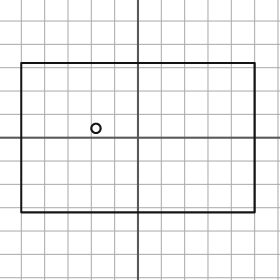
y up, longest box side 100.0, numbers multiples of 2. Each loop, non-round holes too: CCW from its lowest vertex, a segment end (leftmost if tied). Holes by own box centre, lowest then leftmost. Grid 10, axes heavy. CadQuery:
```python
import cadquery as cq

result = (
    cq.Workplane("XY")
    .moveTo(-50.0, -32.0)
    .lineTo(50.0, -32.0)
    .lineTo(50.0, 32.0)
    .lineTo(-50.0, 32.0)
    .close()
    .moveTo(-18.0, 4.0)
    .circle(2.0)
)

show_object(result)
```